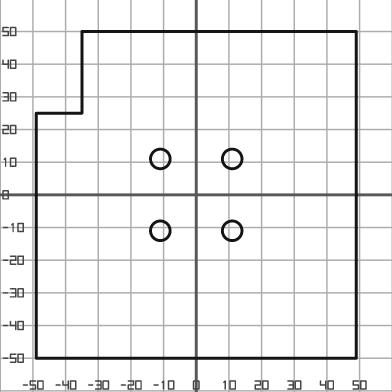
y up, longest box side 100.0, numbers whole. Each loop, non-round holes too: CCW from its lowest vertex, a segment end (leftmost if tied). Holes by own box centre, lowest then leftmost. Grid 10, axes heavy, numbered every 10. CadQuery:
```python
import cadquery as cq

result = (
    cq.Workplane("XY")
    .moveTo(-49.0, -50.0)
    .lineTo(49.0, -50.0)
    .lineTo(49.0, 50.0)
    .lineTo(-35.0, 50.0)
    .lineTo(-35.0, 25.0)
    .lineTo(-49.0, 25.0)
    .close()
    .moveTo(-11.0, -11.0)
    .circle(3.0)
    .moveTo(11.0, -11.0)
    .circle(3.0)
    .moveTo(-11.0, 11.0)
    .circle(3.0)
    .moveTo(11.0, 11.0)
    .circle(3.0)
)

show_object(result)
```